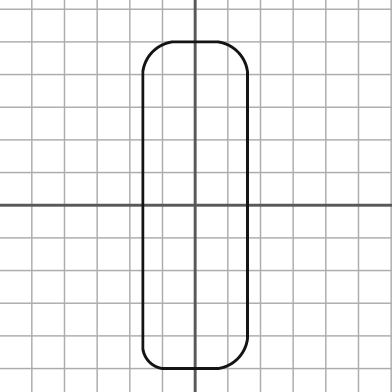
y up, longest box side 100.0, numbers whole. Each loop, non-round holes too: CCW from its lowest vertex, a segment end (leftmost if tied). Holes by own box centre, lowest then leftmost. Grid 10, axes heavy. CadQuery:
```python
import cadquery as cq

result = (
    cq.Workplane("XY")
    .moveTo(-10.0, -50.0)
    .lineTo(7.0, -50.0)
    .threePointArc((13.0, -47.0), (16.0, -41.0))
    .lineTo(16.0, 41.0)
    .threePointArc((13.0, 47.0), (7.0, 50.0))
    .lineTo(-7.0, 50.0)
    .threePointArc((-13.0, 47.0), (-16.0, 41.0))
    .lineTo(-16.0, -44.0)
    .threePointArc((-14.0, -48.0), (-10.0, -50.0))
    .close()
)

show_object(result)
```